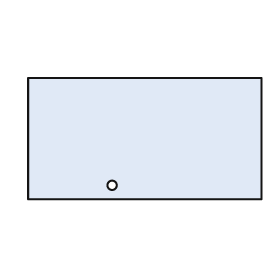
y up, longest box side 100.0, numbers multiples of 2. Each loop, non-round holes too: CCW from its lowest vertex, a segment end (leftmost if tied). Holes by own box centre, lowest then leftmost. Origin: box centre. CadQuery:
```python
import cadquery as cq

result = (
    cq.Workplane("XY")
    .moveTo(-50.0, -26.0)
    .lineTo(50.0, -26.0)
    .lineTo(50.0, 26.0)
    .lineTo(-50.0, 26.0)
    .close()
    .moveTo(-14.0, -20.0)
    .circle(2.0)
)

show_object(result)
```